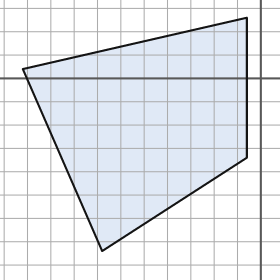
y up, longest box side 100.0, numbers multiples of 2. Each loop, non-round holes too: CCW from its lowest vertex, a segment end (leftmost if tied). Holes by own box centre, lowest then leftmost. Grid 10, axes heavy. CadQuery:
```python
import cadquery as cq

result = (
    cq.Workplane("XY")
    .moveTo(-68.0, -74.0)
    .lineTo(-6.0, -34.0)
    .lineTo(-6.0, 26.0)
    .lineTo(-102.0, 4.0)
    .close()
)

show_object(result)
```